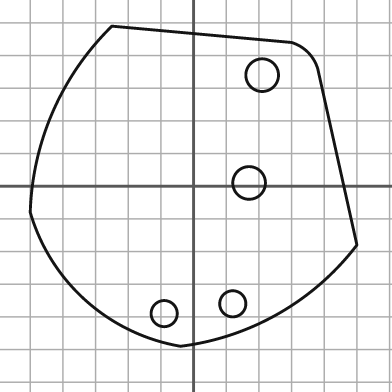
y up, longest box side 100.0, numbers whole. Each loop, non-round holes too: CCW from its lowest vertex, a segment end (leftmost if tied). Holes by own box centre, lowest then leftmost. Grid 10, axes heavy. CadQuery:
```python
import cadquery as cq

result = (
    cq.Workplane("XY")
    .moveTo(-4.0, -49.0)
    .threePointArc((26.0, -39.0), (50.0, -18.0))
    .lineTo(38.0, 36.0)
    .threePointArc((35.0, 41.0), (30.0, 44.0))
    .lineTo(-25.0, 49.0)
    .threePointArc((-43.0, 23.0), (-50.0, -8.0))
    .threePointArc((-33.0, -35.0), (-4.0, -49.0))
    .close()
    .moveTo(-9.0, -39.0)
    .circle(4.0)
    .moveTo(12.0, -36.0)
    .circle(4.0)
    .moveTo(17.0, 1.0)
    .circle(5.0)
    .moveTo(21.0, 34.0)
    .circle(5.0)
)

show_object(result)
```